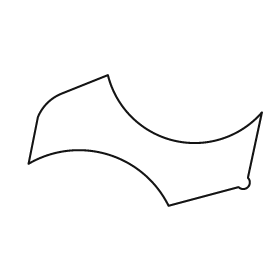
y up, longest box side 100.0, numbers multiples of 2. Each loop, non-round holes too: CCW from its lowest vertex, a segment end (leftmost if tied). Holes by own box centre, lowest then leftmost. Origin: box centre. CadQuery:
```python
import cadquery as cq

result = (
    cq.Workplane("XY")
    .moveTo(10.0, -28.0)
    .lineTo(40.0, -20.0)
    .threePointArc((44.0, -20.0), (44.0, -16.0))
    .lineTo(50.0, 12.0)
    .threePointArc((12.0, 0.0), (-16.0, 28.0))
    .lineTo(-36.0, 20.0)
    .threePointArc((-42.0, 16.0), (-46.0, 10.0))
    .lineTo(-50.0, -10.0)
    .threePointArc((-16.0, -6.0), (10.0, -28.0))
    .close()
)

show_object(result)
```